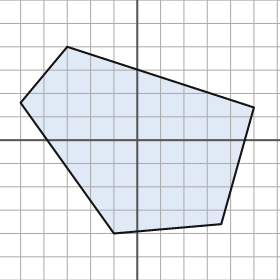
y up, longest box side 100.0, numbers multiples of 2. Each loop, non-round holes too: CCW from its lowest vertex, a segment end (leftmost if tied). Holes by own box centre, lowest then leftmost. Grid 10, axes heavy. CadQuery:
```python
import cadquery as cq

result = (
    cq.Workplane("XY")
    .moveTo(-10.0, -40.0)
    .lineTo(36.0, -36.0)
    .lineTo(50.0, 14.0)
    .lineTo(-30.0, 40.0)
    .lineTo(-50.0, 16.0)
    .close()
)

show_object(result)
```